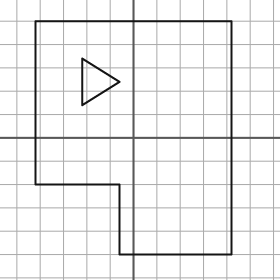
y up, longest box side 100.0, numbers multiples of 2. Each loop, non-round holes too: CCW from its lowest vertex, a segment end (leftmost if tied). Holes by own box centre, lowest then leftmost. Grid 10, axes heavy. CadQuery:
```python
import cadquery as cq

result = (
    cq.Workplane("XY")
    .moveTo(-6.0, -50.0)
    .lineTo(42.0, -50.0)
    .lineTo(42.0, 50.0)
    .lineTo(-42.0, 50.0)
    .lineTo(-42.0, -20.0)
    .lineTo(-6.0, -20.0)
    .close()
    .moveTo(-22.0, 14.0)
    .lineTo(-6.0, 24.0)
    .lineTo(-22.0, 34.0)
    .close()
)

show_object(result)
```